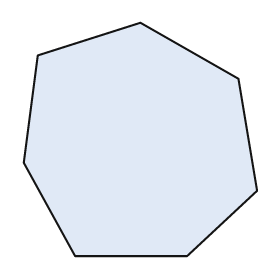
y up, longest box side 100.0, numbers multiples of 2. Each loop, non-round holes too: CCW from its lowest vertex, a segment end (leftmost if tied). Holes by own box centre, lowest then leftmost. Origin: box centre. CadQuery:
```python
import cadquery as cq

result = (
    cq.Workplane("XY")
    .moveTo(-28.0, -50.0)
    .lineTo(20.0, -50.0)
    .lineTo(50.0, -22.0)
    .lineTo(42.0, 26.0)
    .lineTo(0.0, 50.0)
    .lineTo(-44.0, 36.0)
    .lineTo(-50.0, -10.0)
    .close()
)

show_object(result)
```